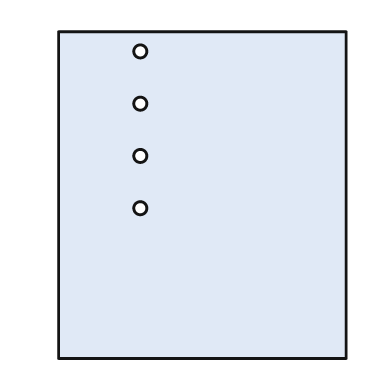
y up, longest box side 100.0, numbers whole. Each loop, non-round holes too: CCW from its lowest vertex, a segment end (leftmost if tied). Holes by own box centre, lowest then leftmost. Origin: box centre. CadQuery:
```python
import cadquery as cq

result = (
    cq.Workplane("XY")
    .moveTo(-44.0, -50.0)
    .lineTo(44.0, -50.0)
    .lineTo(44.0, 50.0)
    .lineTo(-44.0, 50.0)
    .close()
    .moveTo(-19.0, -4.0)
    .circle(2.0)
    .moveTo(-19.0, 12.0)
    .circle(2.0)
    .moveTo(-19.0, 28.0)
    .circle(2.0)
    .moveTo(-19.0, 44.0)
    .circle(2.0)
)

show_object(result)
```